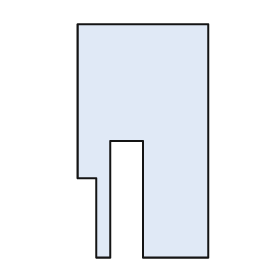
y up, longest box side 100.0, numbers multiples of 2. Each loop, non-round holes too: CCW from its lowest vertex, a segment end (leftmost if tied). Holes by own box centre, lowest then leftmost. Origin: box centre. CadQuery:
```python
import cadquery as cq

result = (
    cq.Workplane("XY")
    .moveTo(-20.0, -50.0)
    .lineTo(-14.0, -50.0)
    .lineTo(-14.0, 0.0)
    .lineTo(0.0, 0.0)
    .lineTo(0.0, -50.0)
    .lineTo(28.0, -50.0)
    .lineTo(28.0, 50.0)
    .lineTo(-28.0, 50.0)
    .lineTo(-28.0, -16.0)
    .lineTo(-20.0, -16.0)
    .close()
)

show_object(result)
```